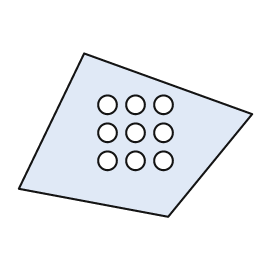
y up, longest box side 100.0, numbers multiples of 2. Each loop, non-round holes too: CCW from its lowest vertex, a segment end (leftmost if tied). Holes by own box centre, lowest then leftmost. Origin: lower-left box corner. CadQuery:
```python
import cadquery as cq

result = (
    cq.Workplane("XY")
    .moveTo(64.0, 0.0)
    .lineTo(100.0, 44.0)
    .lineTo(28.0, 70.0)
    .lineTo(0.0, 12.0)
    .close()
    .moveTo(38.0, 24.0)
    .circle(4.0)
    .moveTo(50.0, 24.0)
    .circle(4.0)
    .moveTo(62.0, 24.0)
    .circle(4.0)
    .moveTo(38.0, 36.0)
    .circle(4.0)
    .moveTo(50.0, 36.0)
    .circle(4.0)
    .moveTo(62.0, 36.0)
    .circle(4.0)
    .moveTo(38.0, 48.0)
    .circle(4.0)
    .moveTo(50.0, 48.0)
    .circle(4.0)
    .moveTo(62.0, 48.0)
    .circle(4.0)
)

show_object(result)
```